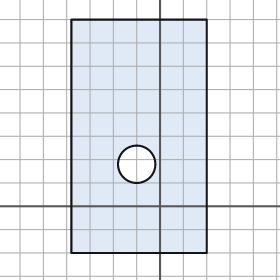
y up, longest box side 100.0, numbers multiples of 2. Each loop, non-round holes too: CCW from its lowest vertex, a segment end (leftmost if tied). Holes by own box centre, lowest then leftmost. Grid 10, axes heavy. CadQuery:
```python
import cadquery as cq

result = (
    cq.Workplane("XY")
    .moveTo(-38.0, -20.0)
    .lineTo(20.0, -20.0)
    .lineTo(20.0, 80.0)
    .lineTo(-38.0, 80.0)
    .close()
    .moveTo(-10.0, 18.0)
    .circle(8.0)
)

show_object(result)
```